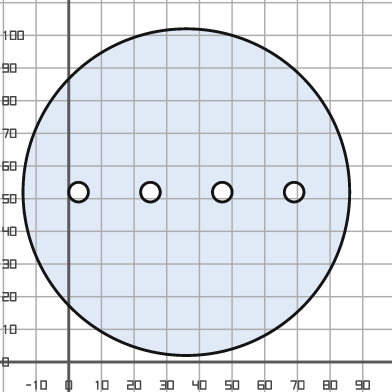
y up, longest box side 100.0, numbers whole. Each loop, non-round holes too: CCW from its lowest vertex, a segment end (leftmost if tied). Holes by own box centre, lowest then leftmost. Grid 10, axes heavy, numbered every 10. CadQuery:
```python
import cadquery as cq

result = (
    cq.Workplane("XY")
    .moveTo(36.0, 52.0)
    .circle(50.0)
    .moveTo(3.0, 52.0)
    .circle(3.0)
    .moveTo(25.0, 52.0)
    .circle(3.0)
    .moveTo(47.0, 52.0)
    .circle(3.0)
    .moveTo(69.0, 52.0)
    .circle(3.0)
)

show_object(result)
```